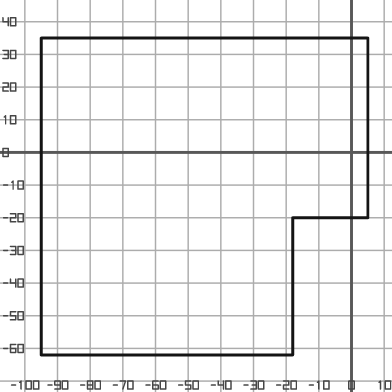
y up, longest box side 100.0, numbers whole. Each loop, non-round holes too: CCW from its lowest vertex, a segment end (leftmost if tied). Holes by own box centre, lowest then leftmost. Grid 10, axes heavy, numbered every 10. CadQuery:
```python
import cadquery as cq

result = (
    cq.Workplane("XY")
    .moveTo(-95.0, -62.0)
    .lineTo(-18.0, -62.0)
    .lineTo(-18.0, -20.0)
    .lineTo(5.0, -20.0)
    .lineTo(5.0, 35.0)
    .lineTo(-95.0, 35.0)
    .close()
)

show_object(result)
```